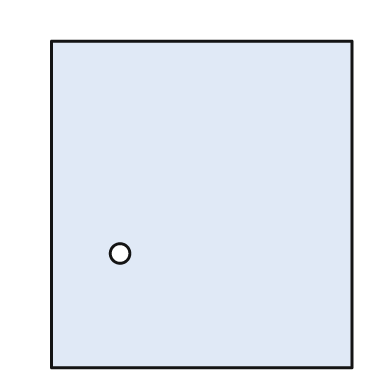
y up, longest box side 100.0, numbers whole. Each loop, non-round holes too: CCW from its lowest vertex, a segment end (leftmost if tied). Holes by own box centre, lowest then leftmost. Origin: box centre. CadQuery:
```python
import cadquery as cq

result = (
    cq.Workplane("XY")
    .moveTo(-46.0, -50.0)
    .lineTo(46.0, -50.0)
    .lineTo(46.0, 50.0)
    .lineTo(-46.0, 50.0)
    .close()
    .moveTo(-25.0, -15.0)
    .circle(3.0)
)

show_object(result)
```